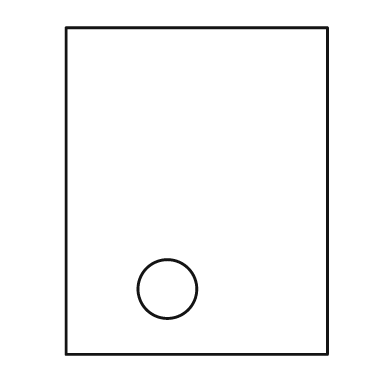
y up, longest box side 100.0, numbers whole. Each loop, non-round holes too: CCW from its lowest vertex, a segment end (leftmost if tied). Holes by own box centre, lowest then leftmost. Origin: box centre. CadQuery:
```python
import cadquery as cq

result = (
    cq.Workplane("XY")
    .moveTo(-40.0, -50.0)
    .lineTo(40.0, -50.0)
    .lineTo(40.0, 50.0)
    .lineTo(-40.0, 50.0)
    .close()
    .moveTo(-9.0, -30.0)
    .circle(9.0)
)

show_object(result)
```